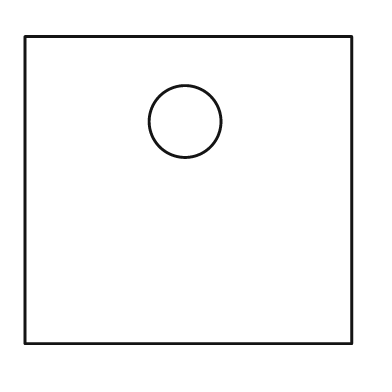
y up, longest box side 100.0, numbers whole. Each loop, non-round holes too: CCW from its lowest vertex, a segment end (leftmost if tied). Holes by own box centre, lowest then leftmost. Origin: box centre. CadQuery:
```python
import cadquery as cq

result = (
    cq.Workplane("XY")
    .moveTo(-50.0, -47.0)
    .lineTo(50.0, -47.0)
    .lineTo(50.0, 47.0)
    .lineTo(-50.0, 47.0)
    .close()
    .moveTo(-1.0, 21.0)
    .circle(11.0)
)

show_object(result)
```